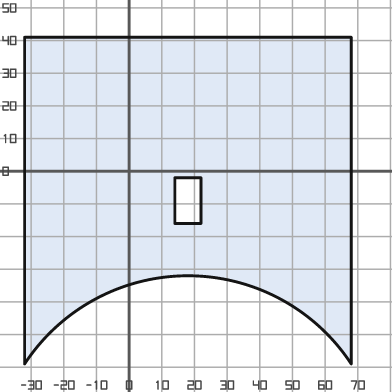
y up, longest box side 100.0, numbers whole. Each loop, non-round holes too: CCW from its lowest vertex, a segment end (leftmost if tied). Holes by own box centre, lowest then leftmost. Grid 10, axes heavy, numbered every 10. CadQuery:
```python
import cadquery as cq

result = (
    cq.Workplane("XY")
    .moveTo(-32.0, -59.0)
    .threePointArc((18.0, -32.0), (68.0, -59.0))
    .lineTo(68.0, 41.0)
    .lineTo(-32.0, 41.0)
    .close()
    .moveTo(14.0, -16.0)
    .lineTo(22.0, -16.0)
    .lineTo(22.0, -2.0)
    .lineTo(14.0, -2.0)
    .close()
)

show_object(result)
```